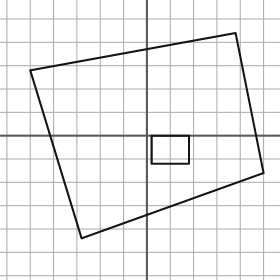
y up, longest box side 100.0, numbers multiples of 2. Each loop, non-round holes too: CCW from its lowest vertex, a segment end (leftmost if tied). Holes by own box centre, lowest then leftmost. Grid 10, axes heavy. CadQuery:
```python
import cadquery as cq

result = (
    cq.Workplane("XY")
    .moveTo(-28.0, -44.0)
    .lineTo(50.0, -16.0)
    .lineTo(38.0, 44.0)
    .lineTo(-50.0, 28.0)
    .close()
    .moveTo(2.0, -12.0)
    .lineTo(18.0, -12.0)
    .lineTo(18.0, 0.0)
    .lineTo(2.0, 0.0)
    .close()
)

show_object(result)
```